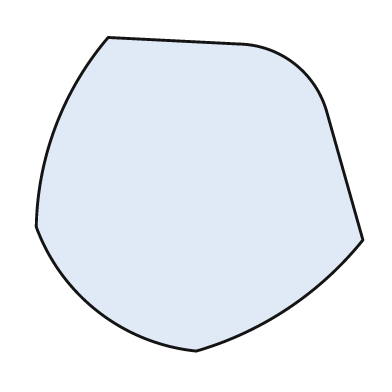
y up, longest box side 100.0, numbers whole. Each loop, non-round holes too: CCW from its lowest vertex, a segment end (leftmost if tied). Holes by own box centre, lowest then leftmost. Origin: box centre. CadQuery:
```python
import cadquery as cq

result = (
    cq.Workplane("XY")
    .moveTo(-1.0, -48.0)
    .threePointArc((27.0, -35.0), (50.0, -14.0))
    .lineTo(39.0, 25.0)
    .threePointArc((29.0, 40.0), (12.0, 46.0))
    .lineTo(-28.0, 48.0)
    .threePointArc((-44.0, 21.0), (-50.0, -10.0))
    .threePointArc((-31.0, -36.0), (-1.0, -48.0))
    .close()
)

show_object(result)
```